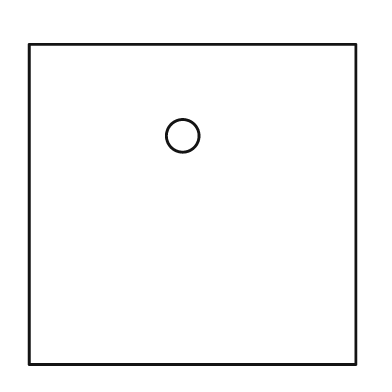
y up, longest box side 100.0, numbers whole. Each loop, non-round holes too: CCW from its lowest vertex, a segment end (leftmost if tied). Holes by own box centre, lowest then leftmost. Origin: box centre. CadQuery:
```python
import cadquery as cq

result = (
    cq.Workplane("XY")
    .moveTo(-50.0, -49.0)
    .lineTo(50.0, -49.0)
    .lineTo(50.0, 49.0)
    .lineTo(-50.0, 49.0)
    .close()
    .moveTo(-3.0, 21.0)
    .circle(5.0)
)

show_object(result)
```